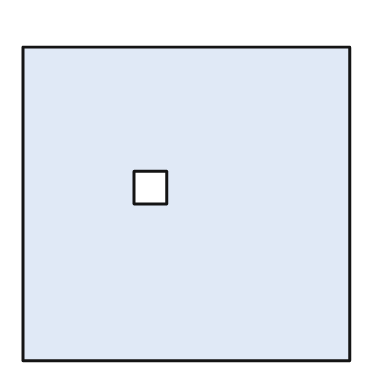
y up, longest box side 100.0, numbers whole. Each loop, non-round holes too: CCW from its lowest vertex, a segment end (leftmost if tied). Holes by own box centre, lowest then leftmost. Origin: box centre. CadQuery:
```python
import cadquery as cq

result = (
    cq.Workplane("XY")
    .moveTo(-50.0, -48.0)
    .lineTo(50.0, -48.0)
    .lineTo(50.0, 48.0)
    .lineTo(-50.0, 48.0)
    .close()
    .moveTo(-16.0, 0.0)
    .lineTo(-6.0, 0.0)
    .lineTo(-6.0, 10.0)
    .lineTo(-16.0, 10.0)
    .close()
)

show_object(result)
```